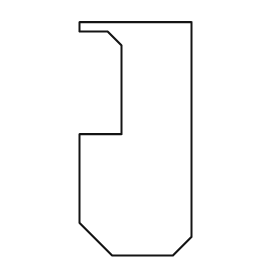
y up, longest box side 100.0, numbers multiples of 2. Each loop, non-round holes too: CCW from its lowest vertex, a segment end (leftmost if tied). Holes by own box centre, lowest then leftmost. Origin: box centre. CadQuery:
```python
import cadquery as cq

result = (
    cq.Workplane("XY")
    .moveTo(-10.0, -50.0)
    .lineTo(16.0, -50.0)
    .lineTo(24.0, -42.0)
    .lineTo(24.0, 50.0)
    .lineTo(-24.0, 50.0)
    .lineTo(-24.0, 46.0)
    .lineTo(-12.0, 46.0)
    .lineTo(-6.0, 40.0)
    .lineTo(-6.0, 2.0)
    .lineTo(-24.0, 2.0)
    .lineTo(-24.0, -36.0)
    .close()
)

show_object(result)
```